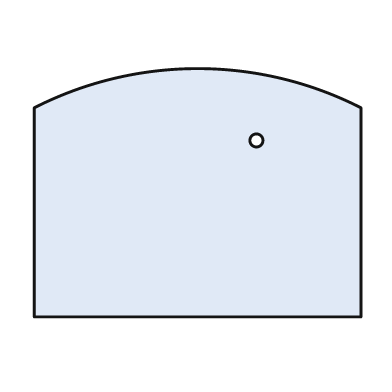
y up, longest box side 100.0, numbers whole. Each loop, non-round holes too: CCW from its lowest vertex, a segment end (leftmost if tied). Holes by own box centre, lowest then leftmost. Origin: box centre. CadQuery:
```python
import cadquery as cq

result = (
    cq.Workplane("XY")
    .moveTo(-50.0, -38.0)
    .lineTo(50.0, -38.0)
    .lineTo(50.0, 26.0)
    .threePointArc((0.0, 38.0), (-50.0, 26.0))
    .close()
    .moveTo(18.0, 16.0)
    .circle(2.0)
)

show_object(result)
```